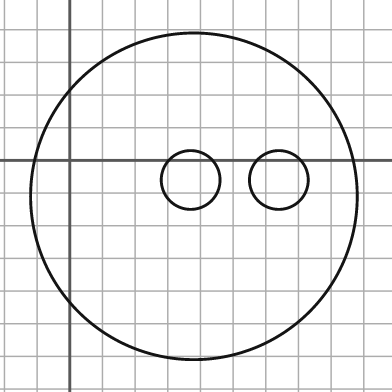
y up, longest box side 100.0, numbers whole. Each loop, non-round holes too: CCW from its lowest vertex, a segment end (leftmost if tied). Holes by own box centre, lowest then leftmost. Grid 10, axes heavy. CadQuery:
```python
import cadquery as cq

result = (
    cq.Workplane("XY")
    .moveTo(38.0, -11.0)
    .circle(50.0)
    .moveTo(37.0, -6.0)
    .circle(9.0)
    .moveTo(64.0, -6.0)
    .circle(9.0)
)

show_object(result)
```